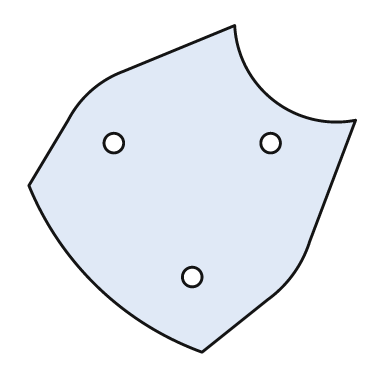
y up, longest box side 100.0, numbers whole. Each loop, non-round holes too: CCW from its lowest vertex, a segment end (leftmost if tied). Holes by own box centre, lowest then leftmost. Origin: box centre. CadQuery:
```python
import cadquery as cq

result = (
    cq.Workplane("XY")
    .moveTo(3.0, -50.0)
    .lineTo(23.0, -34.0)
    .threePointArc((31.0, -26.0), (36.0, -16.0))
    .lineTo(50.0, 21.0)
    .threePointArc((25.0, 27.0), (13.0, 50.0))
    .lineTo(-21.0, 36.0)
    .threePointArc((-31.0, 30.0), (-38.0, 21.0))
    .lineTo(-50.0, 1.0)
    .threePointArc((-29.0, -30.0), (3.0, -50.0))
    .close()
    .moveTo(0.0, -27.0)
    .circle(3.0)
    .moveTo(-24.0, 14.0)
    .circle(3.0)
    .moveTo(24.0, 14.0)
    .circle(3.0)
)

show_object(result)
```